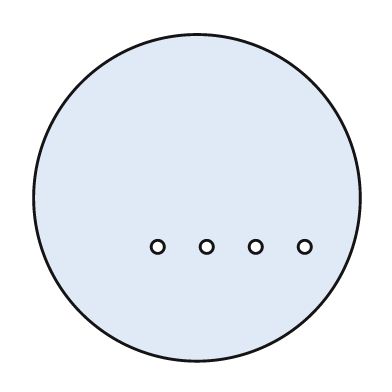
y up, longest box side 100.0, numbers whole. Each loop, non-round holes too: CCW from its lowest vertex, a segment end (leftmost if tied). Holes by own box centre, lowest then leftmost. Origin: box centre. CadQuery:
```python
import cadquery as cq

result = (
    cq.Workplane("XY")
    .moveTo(0.0, 0.0)
    .circle(50.0)
    .moveTo(-12.0, -15.0)
    .circle(2.0)
    .moveTo(3.0, -15.0)
    .circle(2.0)
    .moveTo(18.0, -15.0)
    .circle(2.0)
    .moveTo(33.0, -15.0)
    .circle(2.0)
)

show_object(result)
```